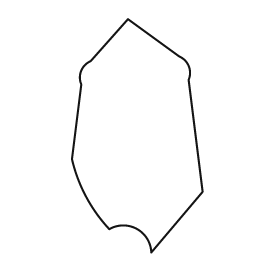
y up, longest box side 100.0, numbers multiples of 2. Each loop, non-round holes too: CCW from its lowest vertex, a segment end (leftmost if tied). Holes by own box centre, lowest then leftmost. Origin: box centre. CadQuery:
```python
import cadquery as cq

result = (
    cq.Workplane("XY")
    .moveTo(6.0, -50.0)
    .lineTo(28.0, -24.0)
    .lineTo(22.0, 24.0)
    .threePointArc((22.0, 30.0), (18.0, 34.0))
    .lineTo(-4.0, 50.0)
    .lineTo(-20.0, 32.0)
    .threePointArc((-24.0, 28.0), (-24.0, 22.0))
    .lineTo(-28.0, -10.0)
    .threePointArc((-22.0, -26.0), (-12.0, -40.0))
    .threePointArc((0.0, -40.0), (6.0, -50.0))
    .close()
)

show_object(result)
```